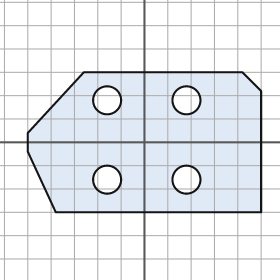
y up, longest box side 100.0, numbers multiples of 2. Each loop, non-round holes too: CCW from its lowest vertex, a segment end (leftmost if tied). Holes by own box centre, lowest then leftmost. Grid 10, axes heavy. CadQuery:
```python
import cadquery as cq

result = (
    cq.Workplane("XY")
    .moveTo(-38.0, -30.0)
    .lineTo(50.0, -30.0)
    .lineTo(50.0, 22.0)
    .lineTo(42.0, 30.0)
    .lineTo(-26.0, 30.0)
    .lineTo(-50.0, 4.0)
    .lineTo(-50.0, -4.0)
    .close()
    .moveTo(-16.0, -16.0)
    .circle(6.0)
    .moveTo(18.0, -16.0)
    .circle(6.0)
    .moveTo(-16.0, 18.0)
    .circle(6.0)
    .moveTo(18.0, 18.0)
    .circle(6.0)
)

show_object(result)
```